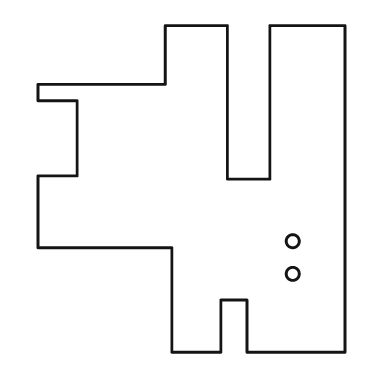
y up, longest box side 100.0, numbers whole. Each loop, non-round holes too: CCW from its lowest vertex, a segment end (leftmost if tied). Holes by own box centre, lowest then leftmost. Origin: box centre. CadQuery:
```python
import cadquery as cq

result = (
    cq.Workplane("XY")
    .moveTo(-6.0, -50.0)
    .lineTo(9.0, -50.0)
    .lineTo(9.0, -34.0)
    .lineTo(17.0, -34.0)
    .lineTo(17.0, -50.0)
    .lineTo(47.0, -50.0)
    .lineTo(47.0, 50.0)
    .lineTo(24.0, 50.0)
    .lineTo(24.0, 3.0)
    .lineTo(11.0, 3.0)
    .lineTo(11.0, 50.0)
    .lineTo(-8.0, 50.0)
    .lineTo(-8.0, 32.0)
    .lineTo(-47.0, 32.0)
    .lineTo(-47.0, 27.0)
    .lineTo(-35.0, 27.0)
    .lineTo(-35.0, 4.0)
    .lineTo(-47.0, 4.0)
    .lineTo(-47.0, -18.0)
    .lineTo(-6.0, -18.0)
    .close()
    .moveTo(31.0, -26.0)
    .circle(2.0)
    .moveTo(31.0, -16.0)
    .circle(2.0)
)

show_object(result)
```